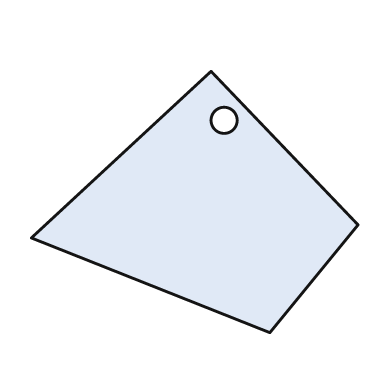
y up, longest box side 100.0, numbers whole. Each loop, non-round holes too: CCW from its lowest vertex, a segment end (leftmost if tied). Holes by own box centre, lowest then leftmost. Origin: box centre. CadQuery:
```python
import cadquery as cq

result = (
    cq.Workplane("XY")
    .moveTo(23.0, -40.0)
    .lineTo(50.0, -7.0)
    .lineTo(5.0, 40.0)
    .lineTo(-50.0, -11.0)
    .close()
    .moveTo(9.0, 25.0)
    .circle(4.0)
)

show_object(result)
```